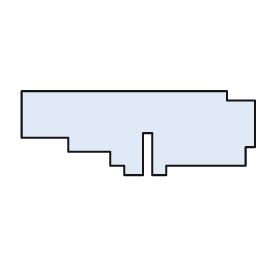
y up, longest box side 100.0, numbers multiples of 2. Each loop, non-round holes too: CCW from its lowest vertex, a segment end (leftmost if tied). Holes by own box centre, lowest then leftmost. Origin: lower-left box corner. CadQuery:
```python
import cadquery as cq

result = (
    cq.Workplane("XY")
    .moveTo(44.0, 0.0)
    .lineTo(52.0, 0.0)
    .lineTo(52.0, 18.0)
    .lineTo(56.0, 18.0)
    .lineTo(56.0, 0.0)
    .lineTo(62.0, 0.0)
    .lineTo(62.0, 4.0)
    .lineTo(96.0, 4.0)
    .lineTo(96.0, 12.0)
    .lineTo(100.0, 12.0)
    .lineTo(100.0, 32.0)
    .lineTo(88.0, 32.0)
    .lineTo(88.0, 36.0)
    .lineTo(0.0, 36.0)
    .lineTo(0.0, 16.0)
    .lineTo(20.0, 16.0)
    .lineTo(20.0, 10.0)
    .lineTo(38.0, 10.0)
    .lineTo(38.0, 4.0)
    .lineTo(44.0, 4.0)
    .close()
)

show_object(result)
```